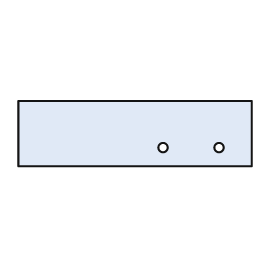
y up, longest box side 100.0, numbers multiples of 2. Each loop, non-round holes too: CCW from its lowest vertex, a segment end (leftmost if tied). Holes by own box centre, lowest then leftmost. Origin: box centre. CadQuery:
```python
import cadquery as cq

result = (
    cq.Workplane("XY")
    .moveTo(-50.0, -14.0)
    .lineTo(50.0, -14.0)
    .lineTo(50.0, 14.0)
    .lineTo(-50.0, 14.0)
    .close()
    .moveTo(12.0, -6.0)
    .circle(2.0)
    .moveTo(36.0, -6.0)
    .circle(2.0)
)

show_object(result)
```